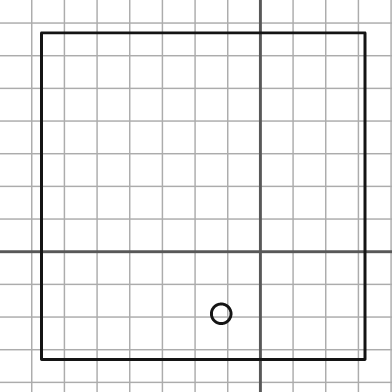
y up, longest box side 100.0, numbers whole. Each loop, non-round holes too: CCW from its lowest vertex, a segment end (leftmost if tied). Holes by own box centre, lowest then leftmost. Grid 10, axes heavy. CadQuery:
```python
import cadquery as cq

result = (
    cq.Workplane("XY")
    .moveTo(-67.0, -33.0)
    .lineTo(32.0, -33.0)
    .lineTo(32.0, 67.0)
    .lineTo(-67.0, 67.0)
    .close()
    .moveTo(-12.0, -19.0)
    .circle(3.0)
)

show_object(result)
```